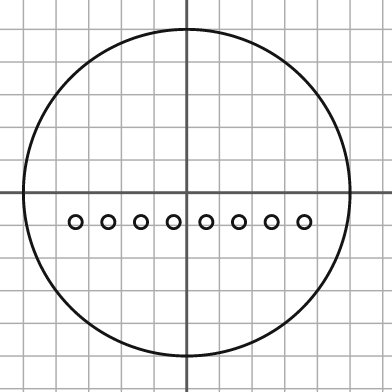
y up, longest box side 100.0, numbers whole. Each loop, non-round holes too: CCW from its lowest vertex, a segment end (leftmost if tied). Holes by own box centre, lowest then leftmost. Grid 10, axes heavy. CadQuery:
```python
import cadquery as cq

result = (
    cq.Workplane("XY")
    .moveTo(0.0, 0.0)
    .circle(50.0)
    .moveTo(-34.0, -9.0)
    .circle(2.0)
    .moveTo(-24.0, -9.0)
    .circle(2.0)
    .moveTo(-14.0, -9.0)
    .circle(2.0)
    .moveTo(-4.0, -9.0)
    .circle(2.0)
    .moveTo(6.0, -9.0)
    .circle(2.0)
    .moveTo(16.0, -9.0)
    .circle(2.0)
    .moveTo(26.0, -9.0)
    .circle(2.0)
    .moveTo(36.0, -9.0)
    .circle(2.0)
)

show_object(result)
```